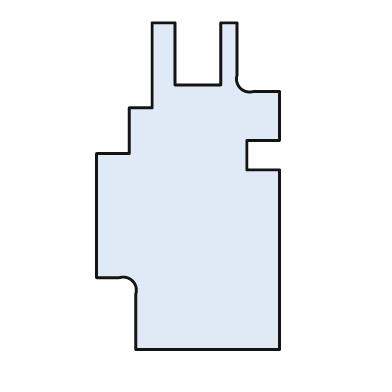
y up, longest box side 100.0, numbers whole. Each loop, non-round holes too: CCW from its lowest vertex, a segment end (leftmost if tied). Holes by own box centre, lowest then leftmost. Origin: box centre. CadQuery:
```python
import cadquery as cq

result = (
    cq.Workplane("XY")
    .moveTo(-16.0, -50.0)
    .lineTo(28.0, -50.0)
    .lineTo(28.0, 5.0)
    .lineTo(18.0, 5.0)
    .lineTo(18.0, 14.0)
    .lineTo(28.0, 14.0)
    .lineTo(28.0, 29.0)
    .lineTo(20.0, 29.0)
    .threePointArc((16.0, 30.0), (15.0, 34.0))
    .lineTo(15.0, 50.0)
    .lineTo(10.0, 50.0)
    .lineTo(10.0, 31.0)
    .lineTo(-4.0, 31.0)
    .lineTo(-4.0, 50.0)
    .lineTo(-11.0, 50.0)
    .lineTo(-11.0, 24.0)
    .lineTo(-18.0, 24.0)
    .lineTo(-18.0, 10.0)
    .lineTo(-28.0, 10.0)
    .lineTo(-28.0, -28.0)
    .lineTo(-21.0, -28.0)
    .threePointArc((-17.0, -29.0), (-16.0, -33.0))
    .close()
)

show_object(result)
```